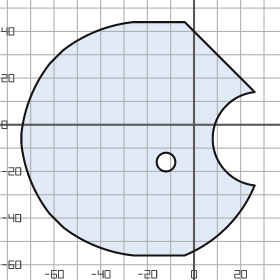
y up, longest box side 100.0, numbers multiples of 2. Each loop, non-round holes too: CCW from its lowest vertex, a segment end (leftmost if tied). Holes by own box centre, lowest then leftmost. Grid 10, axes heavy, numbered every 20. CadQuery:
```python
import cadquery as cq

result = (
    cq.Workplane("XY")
    .moveTo(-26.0, -56.0)
    .lineTo(-4.0, -56.0)
    .threePointArc((14.0, -44.0), (26.0, -26.0))
    .threePointArc((8.0, -6.0), (26.0, 14.0))
    .lineTo(-4.0, 44.0)
    .lineTo(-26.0, 44.0)
    .threePointArc((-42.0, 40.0), (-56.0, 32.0))
    .lineTo(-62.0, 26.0)
    .threePointArc((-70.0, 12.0), (-74.0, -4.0))
    .lineTo(-74.0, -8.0)
    .threePointArc((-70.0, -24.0), (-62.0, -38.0))
    .lineTo(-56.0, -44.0)
    .threePointArc((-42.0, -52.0), (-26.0, -56.0))
    .close()
    .moveTo(-12.0, -16.0)
    .circle(4.0)
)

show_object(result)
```